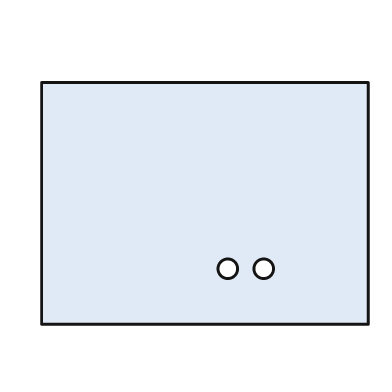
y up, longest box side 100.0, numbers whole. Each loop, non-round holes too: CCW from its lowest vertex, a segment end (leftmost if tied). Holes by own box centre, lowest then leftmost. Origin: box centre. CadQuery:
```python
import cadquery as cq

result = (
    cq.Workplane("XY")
    .moveTo(-50.0, -37.0)
    .lineTo(50.0, -37.0)
    .lineTo(50.0, 37.0)
    .lineTo(-50.0, 37.0)
    .close()
    .moveTo(7.0, -20.0)
    .circle(3.0)
    .moveTo(18.0, -20.0)
    .circle(3.0)
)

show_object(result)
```